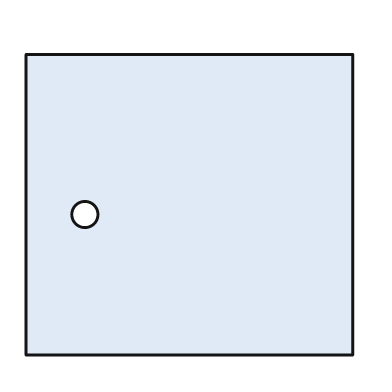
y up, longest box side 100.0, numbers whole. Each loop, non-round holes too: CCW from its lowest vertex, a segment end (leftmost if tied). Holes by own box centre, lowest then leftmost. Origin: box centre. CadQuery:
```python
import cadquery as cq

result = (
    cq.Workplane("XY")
    .moveTo(-50.0, -46.0)
    .lineTo(50.0, -46.0)
    .lineTo(50.0, 46.0)
    .lineTo(-50.0, 46.0)
    .close()
    .moveTo(-32.0, -3.0)
    .circle(4.0)
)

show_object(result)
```